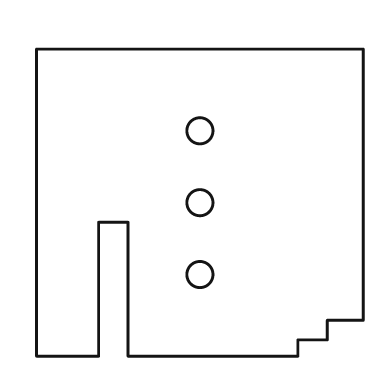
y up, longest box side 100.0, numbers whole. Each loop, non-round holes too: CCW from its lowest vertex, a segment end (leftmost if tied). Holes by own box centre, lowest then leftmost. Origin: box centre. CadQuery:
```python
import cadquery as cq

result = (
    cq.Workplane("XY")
    .moveTo(-50.0, -47.0)
    .lineTo(-31.0, -47.0)
    .lineTo(-31.0, -6.0)
    .lineTo(-22.0, -6.0)
    .lineTo(-22.0, -47.0)
    .lineTo(30.0, -47.0)
    .lineTo(30.0, -42.0)
    .lineTo(39.0, -42.0)
    .lineTo(39.0, -36.0)
    .lineTo(50.0, -36.0)
    .lineTo(50.0, 47.0)
    .lineTo(-50.0, 47.0)
    .close()
    .moveTo(0.0, -22.0)
    .circle(4.0)
    .moveTo(0.0, 0.0)
    .circle(4.0)
    .moveTo(0.0, 22.0)
    .circle(4.0)
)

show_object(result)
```